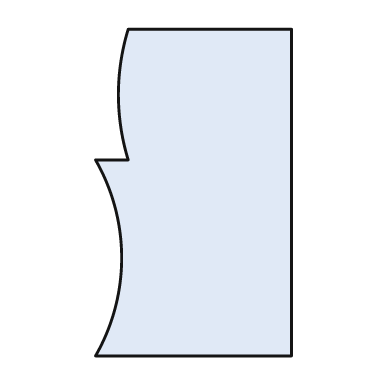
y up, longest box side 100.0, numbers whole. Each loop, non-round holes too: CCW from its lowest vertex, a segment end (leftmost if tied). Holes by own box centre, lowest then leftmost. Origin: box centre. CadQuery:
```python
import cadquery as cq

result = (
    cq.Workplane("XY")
    .moveTo(-30.0, -50.0)
    .lineTo(30.0, -50.0)
    .lineTo(30.0, 50.0)
    .lineTo(-20.0, 50.0)
    .threePointArc((-23.0, 30.0), (-20.0, 10.0))
    .lineTo(-30.0, 10.0)
    .threePointArc((-22.0, -20.0), (-30.0, -50.0))
    .close()
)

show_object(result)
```